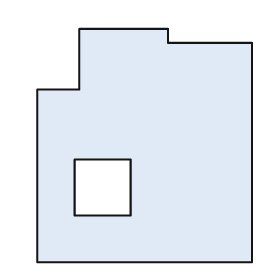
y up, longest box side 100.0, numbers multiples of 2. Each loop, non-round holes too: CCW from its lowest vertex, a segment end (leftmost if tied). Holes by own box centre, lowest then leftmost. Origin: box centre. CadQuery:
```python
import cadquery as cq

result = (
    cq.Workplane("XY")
    .moveTo(-46.0, -50.0)
    .lineTo(46.0, -50.0)
    .lineTo(46.0, 44.0)
    .lineTo(10.0, 44.0)
    .lineTo(10.0, 50.0)
    .lineTo(-28.0, 50.0)
    .lineTo(-28.0, 24.0)
    .lineTo(-46.0, 24.0)
    .close()
    .moveTo(-30.0, -30.0)
    .lineTo(-6.0, -30.0)
    .lineTo(-6.0, -6.0)
    .lineTo(-30.0, -6.0)
    .close()
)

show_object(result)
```